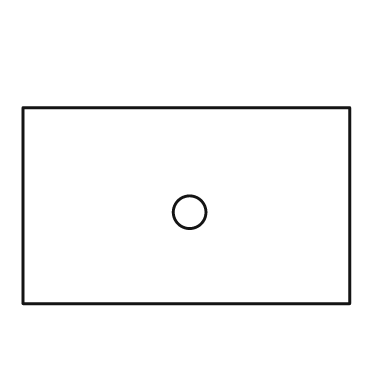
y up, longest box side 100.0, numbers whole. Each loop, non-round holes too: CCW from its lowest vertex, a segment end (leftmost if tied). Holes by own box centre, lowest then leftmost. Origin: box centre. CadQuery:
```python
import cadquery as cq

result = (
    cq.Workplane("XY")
    .moveTo(-50.0, -30.0)
    .lineTo(50.0, -30.0)
    .lineTo(50.0, 30.0)
    .lineTo(-50.0, 30.0)
    .close()
    .moveTo(1.0, -2.0)
    .circle(5.0)
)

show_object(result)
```